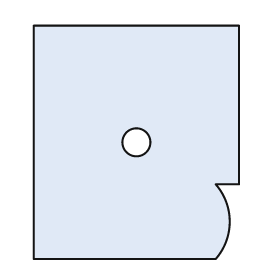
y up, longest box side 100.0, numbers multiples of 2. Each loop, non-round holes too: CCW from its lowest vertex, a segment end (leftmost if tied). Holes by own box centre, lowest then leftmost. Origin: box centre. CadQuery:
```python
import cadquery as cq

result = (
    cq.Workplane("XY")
    .moveTo(-44.0, -50.0)
    .lineTo(34.0, -50.0)
    .threePointArc((40.0, -34.0), (34.0, -18.0))
    .lineTo(44.0, -18.0)
    .lineTo(44.0, 50.0)
    .lineTo(-44.0, 50.0)
    .close()
    .moveTo(0.0, 0.0)
    .circle(6.0)
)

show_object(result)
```